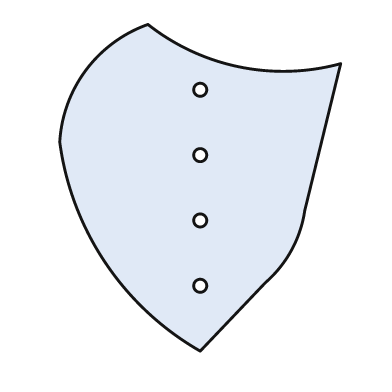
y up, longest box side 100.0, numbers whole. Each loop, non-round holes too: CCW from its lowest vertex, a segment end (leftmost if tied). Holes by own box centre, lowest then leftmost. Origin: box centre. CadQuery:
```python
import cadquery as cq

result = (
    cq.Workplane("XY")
    .moveTo(0.0, -50.0)
    .lineTo(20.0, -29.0)
    .threePointArc((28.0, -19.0), (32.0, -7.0))
    .lineTo(43.0, 38.0)
    .threePointArc((12.0, 37.0), (-16.0, 50.0))
    .threePointArc((-35.0, 36.0), (-43.0, 14.0))
    .threePointArc((-29.0, -23.0), (0.0, -50.0))
    .close()
    .moveTo(0.0, -30.0)
    .circle(2.0)
    .moveTo(0.0, -10.0)
    .circle(2.0)
    .moveTo(0.0, 10.0)
    .circle(2.0)
    .moveTo(0.0, 30.0)
    .circle(2.0)
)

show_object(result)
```